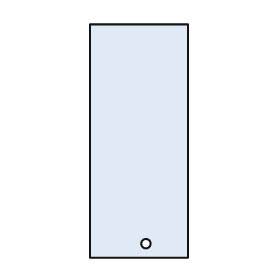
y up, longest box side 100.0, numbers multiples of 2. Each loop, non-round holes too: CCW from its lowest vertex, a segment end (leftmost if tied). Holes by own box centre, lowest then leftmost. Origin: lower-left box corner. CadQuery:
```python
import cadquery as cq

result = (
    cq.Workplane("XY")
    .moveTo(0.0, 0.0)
    .lineTo(42.0, 0.0)
    .lineTo(42.0, 100.0)
    .lineTo(0.0, 100.0)
    .close()
    .moveTo(24.0, 6.0)
    .circle(2.0)
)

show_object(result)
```